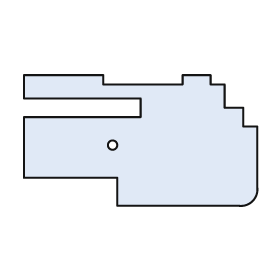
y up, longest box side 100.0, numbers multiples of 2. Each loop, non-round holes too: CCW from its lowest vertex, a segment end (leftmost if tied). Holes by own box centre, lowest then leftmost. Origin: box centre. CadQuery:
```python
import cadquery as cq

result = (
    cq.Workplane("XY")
    .moveTo(-10.0, -28.0)
    .lineTo(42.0, -28.0)
    .threePointArc((48.0, -26.0), (50.0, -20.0))
    .lineTo(50.0, 6.0)
    .lineTo(44.0, 6.0)
    .lineTo(44.0, 14.0)
    .lineTo(36.0, 14.0)
    .lineTo(36.0, 24.0)
    .lineTo(30.0, 24.0)
    .lineTo(30.0, 28.0)
    .lineTo(18.0, 28.0)
    .lineTo(18.0, 24.0)
    .lineTo(-16.0, 24.0)
    .lineTo(-16.0, 28.0)
    .lineTo(-50.0, 28.0)
    .lineTo(-50.0, 18.0)
    .lineTo(0.0, 18.0)
    .lineTo(0.0, 10.0)
    .lineTo(-50.0, 10.0)
    .lineTo(-50.0, -16.0)
    .lineTo(-10.0, -16.0)
    .close()
    .moveTo(-12.0, -2.0)
    .circle(2.0)
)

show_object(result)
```